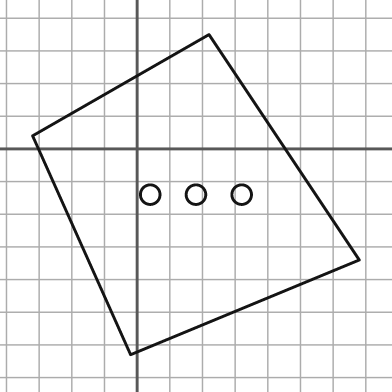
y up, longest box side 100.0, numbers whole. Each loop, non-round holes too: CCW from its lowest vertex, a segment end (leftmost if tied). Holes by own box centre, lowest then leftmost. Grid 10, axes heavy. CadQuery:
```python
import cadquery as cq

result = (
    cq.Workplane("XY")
    .moveTo(-2.0, -63.0)
    .lineTo(68.0, -34.0)
    .lineTo(22.0, 35.0)
    .lineTo(-32.0, 4.0)
    .close()
    .moveTo(4.0, -14.0)
    .circle(3.0)
    .moveTo(18.0, -14.0)
    .circle(3.0)
    .moveTo(32.0, -14.0)
    .circle(3.0)
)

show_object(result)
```